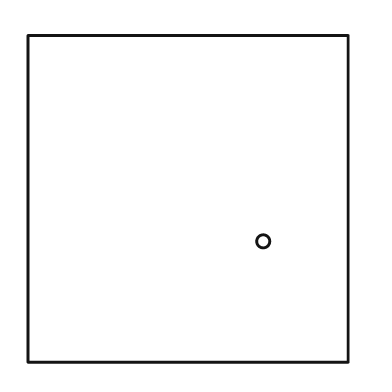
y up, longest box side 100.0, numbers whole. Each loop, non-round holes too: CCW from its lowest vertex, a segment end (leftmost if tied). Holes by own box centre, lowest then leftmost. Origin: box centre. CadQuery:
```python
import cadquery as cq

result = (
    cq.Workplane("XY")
    .moveTo(-49.0, -50.0)
    .lineTo(49.0, -50.0)
    .lineTo(49.0, 50.0)
    .lineTo(-49.0, 50.0)
    .close()
    .moveTo(23.0, -13.0)
    .circle(2.0)
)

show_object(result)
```